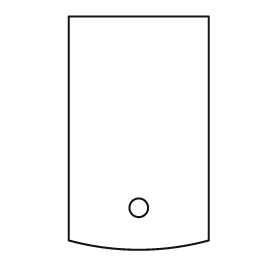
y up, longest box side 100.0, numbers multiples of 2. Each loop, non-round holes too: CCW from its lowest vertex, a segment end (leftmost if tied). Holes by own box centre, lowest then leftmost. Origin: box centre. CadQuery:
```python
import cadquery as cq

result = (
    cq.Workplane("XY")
    .moveTo(-30.0, -46.0)
    .threePointArc((0.0, -50.0), (30.0, -46.0))
    .lineTo(30.0, 50.0)
    .lineTo(-30.0, 50.0)
    .close()
    .moveTo(0.0, -32.0)
    .circle(4.0)
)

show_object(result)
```